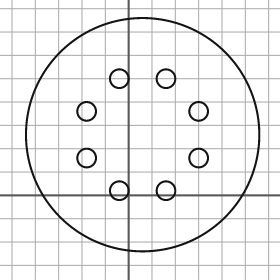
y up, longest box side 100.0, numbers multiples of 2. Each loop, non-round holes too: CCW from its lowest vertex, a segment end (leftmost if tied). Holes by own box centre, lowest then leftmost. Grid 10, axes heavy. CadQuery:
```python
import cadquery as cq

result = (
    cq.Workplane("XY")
    .moveTo(6.0, 26.0)
    .circle(50.0)
    .moveTo(-4.0, 2.0)
    .circle(4.0)
    .moveTo(16.0, 2.0)
    .circle(4.0)
    .moveTo(-18.0, 16.0)
    .circle(4.0)
    .moveTo(30.0, 16.0)
    .circle(4.0)
    .moveTo(-18.0, 36.0)
    .circle(4.0)
    .moveTo(30.0, 36.0)
    .circle(4.0)
    .moveTo(-4.0, 50.0)
    .circle(4.0)
    .moveTo(16.0, 50.0)
    .circle(4.0)
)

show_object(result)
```